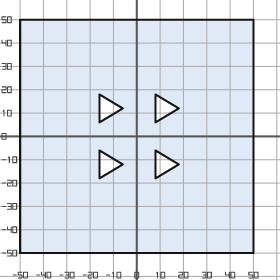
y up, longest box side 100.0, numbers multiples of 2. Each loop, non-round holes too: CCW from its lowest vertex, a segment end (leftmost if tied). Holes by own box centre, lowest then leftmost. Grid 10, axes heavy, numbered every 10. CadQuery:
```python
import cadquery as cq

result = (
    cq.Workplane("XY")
    .moveTo(-50.0, -50.0)
    .lineTo(50.0, -50.0)
    .lineTo(50.0, 50.0)
    .lineTo(-50.0, 50.0)
    .close()
    .moveTo(-16.0, -18.0)
    .lineTo(-6.0, -12.0)
    .lineTo(-16.0, -6.0)
    .close()
    .moveTo(8.0, -18.0)
    .lineTo(18.0, -12.0)
    .lineTo(8.0, -6.0)
    .close()
    .moveTo(-16.0, 6.0)
    .lineTo(-6.0, 12.0)
    .lineTo(-16.0, 18.0)
    .close()
    .moveTo(8.0, 6.0)
    .lineTo(18.0, 12.0)
    .lineTo(8.0, 18.0)
    .close()
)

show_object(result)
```